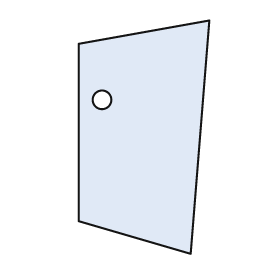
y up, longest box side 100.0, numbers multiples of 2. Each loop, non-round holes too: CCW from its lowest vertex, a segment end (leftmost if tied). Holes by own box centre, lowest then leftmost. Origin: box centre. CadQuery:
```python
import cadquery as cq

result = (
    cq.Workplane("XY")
    .moveTo(20.0, -50.0)
    .lineTo(28.0, 50.0)
    .lineTo(-28.0, 40.0)
    .lineTo(-28.0, -36.0)
    .close()
    .moveTo(-18.0, 16.0)
    .circle(4.0)
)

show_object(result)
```